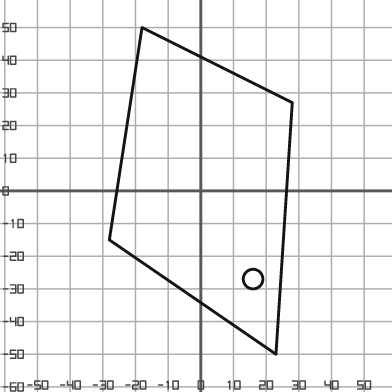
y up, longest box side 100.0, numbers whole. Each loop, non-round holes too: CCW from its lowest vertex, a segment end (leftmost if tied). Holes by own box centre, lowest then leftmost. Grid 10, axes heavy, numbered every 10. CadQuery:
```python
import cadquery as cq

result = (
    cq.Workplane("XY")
    .moveTo(23.0, -50.0)
    .lineTo(28.0, 27.0)
    .lineTo(-18.0, 50.0)
    .lineTo(-28.0, -15.0)
    .close()
    .moveTo(16.0, -27.0)
    .circle(3.0)
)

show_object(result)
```